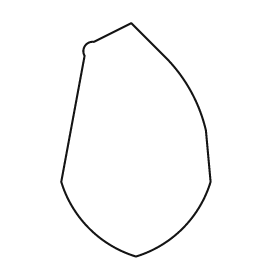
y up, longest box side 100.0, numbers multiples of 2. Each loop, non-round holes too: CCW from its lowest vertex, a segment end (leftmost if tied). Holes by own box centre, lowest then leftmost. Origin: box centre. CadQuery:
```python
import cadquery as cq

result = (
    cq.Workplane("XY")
    .moveTo(0.0, -50.0)
    .threePointArc((20.0, -38.0), (32.0, -18.0))
    .lineTo(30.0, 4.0)
    .threePointArc((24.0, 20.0), (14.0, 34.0))
    .lineTo(-2.0, 50.0)
    .lineTo(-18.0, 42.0)
    .threePointArc((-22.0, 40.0), (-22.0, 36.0))
    .lineTo(-32.0, -18.0)
    .threePointArc((-20.0, -38.0), (0.0, -50.0))
    .close()
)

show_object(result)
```